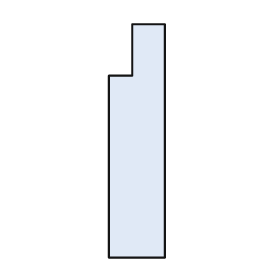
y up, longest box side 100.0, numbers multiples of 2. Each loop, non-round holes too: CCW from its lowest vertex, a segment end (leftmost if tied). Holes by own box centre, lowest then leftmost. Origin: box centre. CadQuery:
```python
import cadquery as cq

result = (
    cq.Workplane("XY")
    .moveTo(-12.0, -50.0)
    .lineTo(12.0, -50.0)
    .lineTo(12.0, 50.0)
    .lineTo(-2.0, 50.0)
    .lineTo(-2.0, 28.0)
    .lineTo(-12.0, 28.0)
    .close()
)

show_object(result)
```